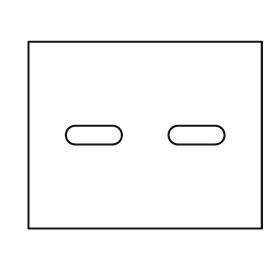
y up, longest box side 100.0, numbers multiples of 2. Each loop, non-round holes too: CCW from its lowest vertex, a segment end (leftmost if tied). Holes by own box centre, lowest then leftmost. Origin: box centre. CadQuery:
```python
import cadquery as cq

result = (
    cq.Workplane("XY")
    .moveTo(-50.0, -40.0)
    .lineTo(50.0, -40.0)
    .lineTo(50.0, 40.0)
    .lineTo(-50.0, 40.0)
    .close()
    .moveTo(-30.0, -4.0)
    .lineTo(-14.0, -4.0)
    .threePointArc((-10.0, 0.0), (-14.0, 4.0))
    .lineTo(-30.0, 4.0)
    .threePointArc((-34.0, 0.0), (-30.0, -4.0))
    .close()
    .moveTo(14.0, -4.0)
    .lineTo(30.0, -4.0)
    .threePointArc((34.0, 0.0), (30.0, 4.0))
    .lineTo(14.0, 4.0)
    .threePointArc((10.0, 0.0), (14.0, -4.0))
    .close()
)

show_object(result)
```